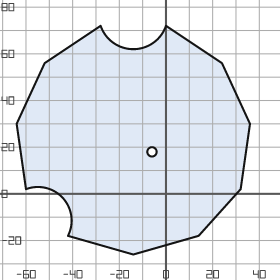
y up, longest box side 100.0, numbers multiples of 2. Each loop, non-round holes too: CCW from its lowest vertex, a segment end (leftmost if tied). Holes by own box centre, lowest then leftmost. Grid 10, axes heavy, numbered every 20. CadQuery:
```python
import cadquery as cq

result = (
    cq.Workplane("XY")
    .moveTo(-14.0, -26.0)
    .lineTo(14.0, -18.0)
    .lineTo(32.0, 2.0)
    .lineTo(36.0, 30.0)
    .lineTo(24.0, 56.0)
    .lineTo(0.0, 72.0)
    .threePointArc((-14.0, 62.0), (-28.0, 72.0))
    .lineTo(-52.0, 56.0)
    .lineTo(-64.0, 30.0)
    .lineTo(-60.0, 2.0)
    .threePointArc((-44.0, -2.0), (-42.0, -18.0))
    .close()
    .moveTo(-6.0, 18.0)
    .circle(2.0)
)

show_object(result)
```